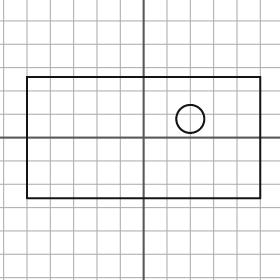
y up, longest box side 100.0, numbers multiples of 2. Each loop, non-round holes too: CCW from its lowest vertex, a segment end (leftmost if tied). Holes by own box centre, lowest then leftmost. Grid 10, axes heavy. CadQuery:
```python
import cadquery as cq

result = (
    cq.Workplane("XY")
    .moveTo(-50.0, -26.0)
    .lineTo(50.0, -26.0)
    .lineTo(50.0, 26.0)
    .lineTo(-50.0, 26.0)
    .close()
    .moveTo(20.0, 8.0)
    .circle(6.0)
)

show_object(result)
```